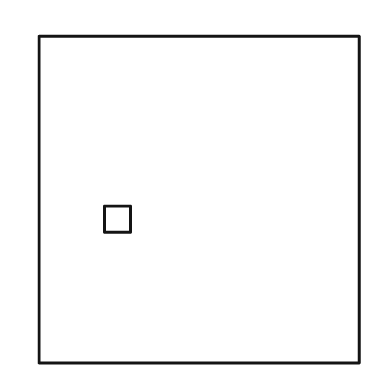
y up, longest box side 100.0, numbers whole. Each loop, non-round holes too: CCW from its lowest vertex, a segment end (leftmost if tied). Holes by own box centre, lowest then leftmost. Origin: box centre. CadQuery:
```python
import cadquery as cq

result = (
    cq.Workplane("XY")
    .moveTo(-49.0, -50.0)
    .lineTo(49.0, -50.0)
    .lineTo(49.0, 50.0)
    .lineTo(-49.0, 50.0)
    .close()
    .moveTo(-29.0, -10.0)
    .lineTo(-21.0, -10.0)
    .lineTo(-21.0, -2.0)
    .lineTo(-29.0, -2.0)
    .close()
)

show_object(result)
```